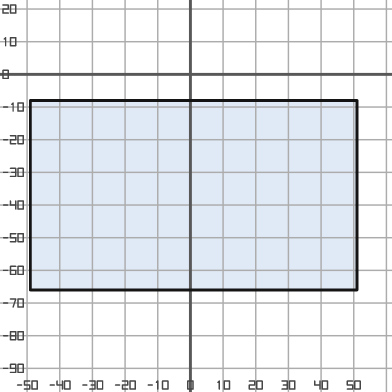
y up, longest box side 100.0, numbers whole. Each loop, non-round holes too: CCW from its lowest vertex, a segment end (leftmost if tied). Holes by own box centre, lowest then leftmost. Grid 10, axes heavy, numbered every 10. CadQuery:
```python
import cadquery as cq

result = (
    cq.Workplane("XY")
    .moveTo(-49.0, -66.0)
    .lineTo(51.0, -66.0)
    .lineTo(51.0, -8.0)
    .lineTo(-49.0, -8.0)
    .close()
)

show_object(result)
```